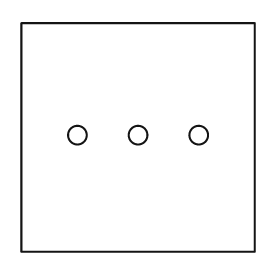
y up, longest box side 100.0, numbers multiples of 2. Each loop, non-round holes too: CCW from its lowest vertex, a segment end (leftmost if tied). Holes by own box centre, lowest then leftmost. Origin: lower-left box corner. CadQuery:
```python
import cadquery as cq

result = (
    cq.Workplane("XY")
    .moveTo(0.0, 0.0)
    .lineTo(100.0, 0.0)
    .lineTo(100.0, 98.0)
    .lineTo(0.0, 98.0)
    .close()
    .moveTo(24.0, 50.0)
    .circle(4.0)
    .moveTo(50.0, 50.0)
    .circle(4.0)
    .moveTo(76.0, 50.0)
    .circle(4.0)
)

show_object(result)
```